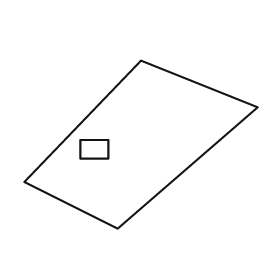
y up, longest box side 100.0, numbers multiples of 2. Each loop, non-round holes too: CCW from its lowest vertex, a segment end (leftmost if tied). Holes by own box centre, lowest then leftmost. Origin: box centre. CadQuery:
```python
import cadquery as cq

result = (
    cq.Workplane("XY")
    .moveTo(-10.0, -36.0)
    .lineTo(50.0, 16.0)
    .lineTo(0.0, 36.0)
    .lineTo(-50.0, -16.0)
    .close()
    .moveTo(-26.0, -6.0)
    .lineTo(-14.0, -6.0)
    .lineTo(-14.0, 2.0)
    .lineTo(-26.0, 2.0)
    .close()
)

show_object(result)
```